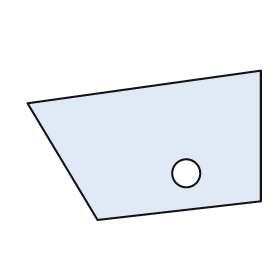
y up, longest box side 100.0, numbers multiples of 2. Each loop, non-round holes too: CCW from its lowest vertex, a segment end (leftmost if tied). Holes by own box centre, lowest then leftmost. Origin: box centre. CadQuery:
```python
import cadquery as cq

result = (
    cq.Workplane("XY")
    .moveTo(-20.0, -32.0)
    .lineTo(50.0, -24.0)
    .lineTo(50.0, 32.0)
    .lineTo(-50.0, 18.0)
    .close()
    .moveTo(18.0, -12.0)
    .circle(6.0)
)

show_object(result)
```